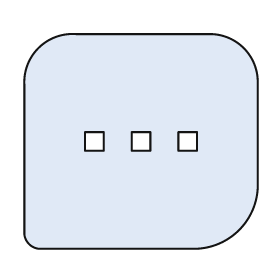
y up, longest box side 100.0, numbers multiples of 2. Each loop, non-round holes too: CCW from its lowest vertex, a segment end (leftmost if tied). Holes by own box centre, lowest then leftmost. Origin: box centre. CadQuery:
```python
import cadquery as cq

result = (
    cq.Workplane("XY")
    .moveTo(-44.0, -46.0)
    .lineTo(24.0, -46.0)
    .threePointArc((42.0, -38.0), (50.0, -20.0))
    .lineTo(50.0, 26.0)
    .threePointArc((44.0, 40.0), (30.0, 46.0))
    .lineTo(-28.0, 46.0)
    .threePointArc((-44.0, 40.0), (-50.0, 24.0))
    .lineTo(-50.0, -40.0)
    .threePointArc((-48.0, -44.0), (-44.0, -46.0))
    .close()
    .moveTo(-24.0, -4.0)
    .lineTo(-16.0, -4.0)
    .lineTo(-16.0, 4.0)
    .lineTo(-24.0, 4.0)
    .close()
    .moveTo(-4.0, -4.0)
    .lineTo(4.0, -4.0)
    .lineTo(4.0, 4.0)
    .lineTo(-4.0, 4.0)
    .close()
    .moveTo(16.0, -4.0)
    .lineTo(24.0, -4.0)
    .lineTo(24.0, 4.0)
    .lineTo(16.0, 4.0)
    .close()
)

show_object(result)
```